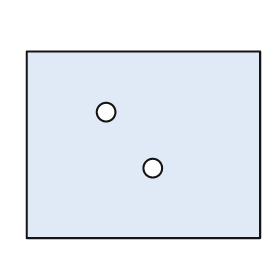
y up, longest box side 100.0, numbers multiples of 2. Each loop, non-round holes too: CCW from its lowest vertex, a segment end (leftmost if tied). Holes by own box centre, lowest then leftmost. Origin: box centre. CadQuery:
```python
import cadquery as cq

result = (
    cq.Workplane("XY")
    .moveTo(-50.0, -40.0)
    .lineTo(50.0, -40.0)
    .lineTo(50.0, 40.0)
    .lineTo(-50.0, 40.0)
    .close()
    .moveTo(4.0, -10.0)
    .circle(4.0)
    .moveTo(-16.0, 14.0)
    .circle(4.0)
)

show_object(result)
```